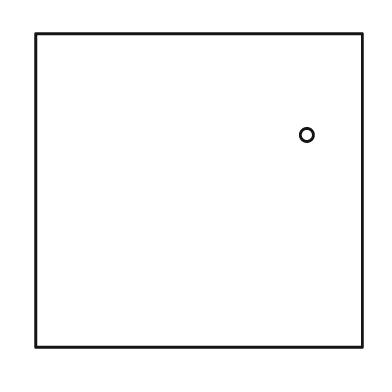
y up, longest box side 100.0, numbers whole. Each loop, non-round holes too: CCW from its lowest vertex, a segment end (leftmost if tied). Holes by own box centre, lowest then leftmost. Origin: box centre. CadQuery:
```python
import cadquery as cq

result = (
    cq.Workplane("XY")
    .moveTo(-50.0, -48.0)
    .lineTo(50.0, -48.0)
    .lineTo(50.0, 48.0)
    .lineTo(-50.0, 48.0)
    .close()
    .moveTo(33.0, 17.0)
    .circle(2.0)
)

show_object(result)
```